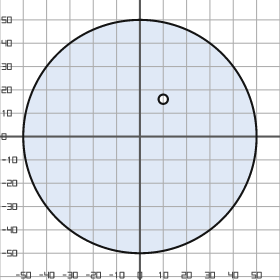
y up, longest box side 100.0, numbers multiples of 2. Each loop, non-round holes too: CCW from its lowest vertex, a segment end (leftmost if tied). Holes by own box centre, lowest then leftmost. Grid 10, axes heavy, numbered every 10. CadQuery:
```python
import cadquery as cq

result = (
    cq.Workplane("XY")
    .moveTo(0.0, 0.0)
    .circle(50.0)
    .moveTo(10.0, 16.0)
    .circle(2.0)
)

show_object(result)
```